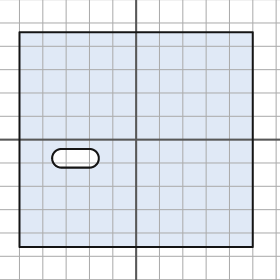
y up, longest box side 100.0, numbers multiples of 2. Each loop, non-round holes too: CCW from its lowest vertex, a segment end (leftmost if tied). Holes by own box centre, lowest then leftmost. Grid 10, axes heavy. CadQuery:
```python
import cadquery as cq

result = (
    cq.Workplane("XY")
    .moveTo(-50.0, -46.0)
    .lineTo(50.0, -46.0)
    .lineTo(50.0, 46.0)
    .lineTo(-50.0, 46.0)
    .close()
    .moveTo(-32.0, -12.0)
    .lineTo(-20.0, -12.0)
    .threePointArc((-16.0, -8.0), (-20.0, -4.0))
    .lineTo(-32.0, -4.0)
    .threePointArc((-36.0, -8.0), (-32.0, -12.0))
    .close()
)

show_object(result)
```